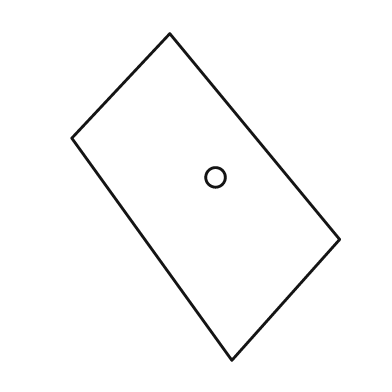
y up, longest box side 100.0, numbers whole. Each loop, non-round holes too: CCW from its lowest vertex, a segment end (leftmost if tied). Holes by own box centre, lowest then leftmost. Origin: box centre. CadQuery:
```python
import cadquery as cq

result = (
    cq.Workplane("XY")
    .moveTo(8.0, -50.0)
    .lineTo(41.0, -13.0)
    .lineTo(-11.0, 50.0)
    .lineTo(-41.0, 18.0)
    .close()
    .moveTo(3.0, 6.0)
    .circle(3.0)
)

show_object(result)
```